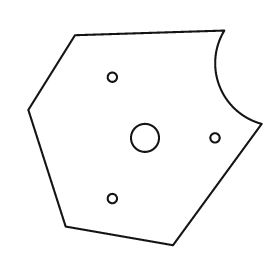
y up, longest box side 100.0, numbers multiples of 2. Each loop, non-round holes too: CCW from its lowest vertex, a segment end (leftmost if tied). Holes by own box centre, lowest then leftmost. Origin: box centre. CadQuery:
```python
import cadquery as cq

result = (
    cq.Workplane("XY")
    .moveTo(12.0, -46.0)
    .lineTo(50.0, 6.0)
    .threePointArc((32.0, 22.0), (34.0, 46.0))
    .lineTo(-30.0, 44.0)
    .lineTo(-50.0, 12.0)
    .lineTo(-34.0, -38.0)
    .close()
    .moveTo(-14.0, -26.0)
    .circle(2.0)
    .moveTo(0.0, 0.0)
    .circle(6.0)
    .moveTo(30.0, 0.0)
    .circle(2.0)
    .moveTo(-14.0, 26.0)
    .circle(2.0)
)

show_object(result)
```